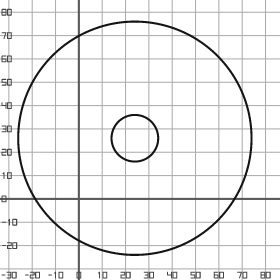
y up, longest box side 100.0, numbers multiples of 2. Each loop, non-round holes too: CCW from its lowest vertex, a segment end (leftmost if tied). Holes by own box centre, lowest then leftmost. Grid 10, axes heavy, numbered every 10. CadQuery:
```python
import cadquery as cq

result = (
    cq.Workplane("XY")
    .moveTo(24.0, 26.0)
    .circle(50.0)
    .moveTo(24.0, 26.0)
    .circle(10.0)
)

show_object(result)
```